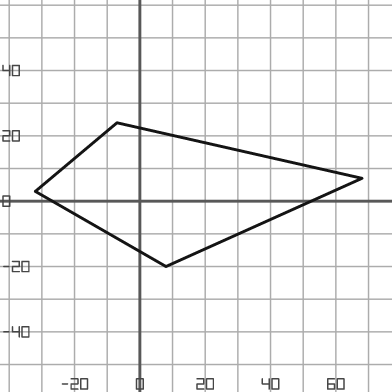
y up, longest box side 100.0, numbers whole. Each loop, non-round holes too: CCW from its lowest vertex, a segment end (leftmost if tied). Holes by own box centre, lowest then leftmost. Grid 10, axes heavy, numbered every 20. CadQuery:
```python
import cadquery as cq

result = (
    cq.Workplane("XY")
    .moveTo(8.0, -20.0)
    .lineTo(68.0, 7.0)
    .lineTo(-7.0, 24.0)
    .lineTo(-32.0, 3.0)
    .close()
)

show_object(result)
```